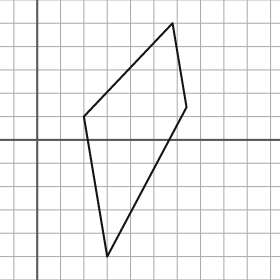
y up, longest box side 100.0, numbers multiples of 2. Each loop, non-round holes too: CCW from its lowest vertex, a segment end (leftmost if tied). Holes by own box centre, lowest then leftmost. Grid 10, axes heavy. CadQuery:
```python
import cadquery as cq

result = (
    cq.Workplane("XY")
    .moveTo(30.0, -50.0)
    .lineTo(64.0, 14.0)
    .lineTo(58.0, 50.0)
    .lineTo(20.0, 10.0)
    .close()
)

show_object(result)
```